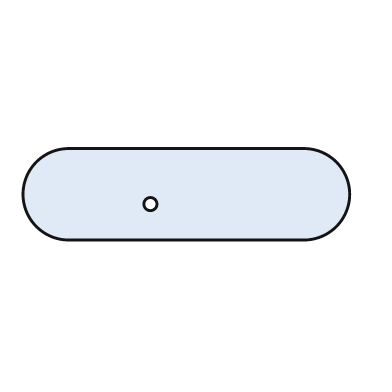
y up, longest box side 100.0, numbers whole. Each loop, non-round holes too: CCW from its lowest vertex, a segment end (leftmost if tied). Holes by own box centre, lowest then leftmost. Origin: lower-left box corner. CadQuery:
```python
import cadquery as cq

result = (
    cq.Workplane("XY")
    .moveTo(14.0, 0.0)
    .lineTo(86.0, 0.0)
    .threePointArc((100.0, 14.0), (86.0, 28.0))
    .lineTo(14.0, 28.0)
    .threePointArc((0.0, 14.0), (14.0, 0.0))
    .close()
    .moveTo(39.0, 11.0)
    .circle(2.0)
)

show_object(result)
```